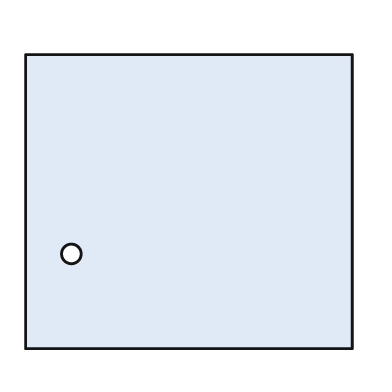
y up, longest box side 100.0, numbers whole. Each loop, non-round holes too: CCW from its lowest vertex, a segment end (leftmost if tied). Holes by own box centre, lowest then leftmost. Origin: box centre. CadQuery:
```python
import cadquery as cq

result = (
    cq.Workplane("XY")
    .moveTo(-50.0, -45.0)
    .lineTo(50.0, -45.0)
    .lineTo(50.0, 45.0)
    .lineTo(-50.0, 45.0)
    .close()
    .moveTo(-36.0, -16.0)
    .circle(3.0)
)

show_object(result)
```